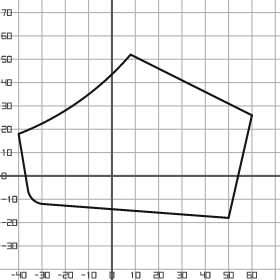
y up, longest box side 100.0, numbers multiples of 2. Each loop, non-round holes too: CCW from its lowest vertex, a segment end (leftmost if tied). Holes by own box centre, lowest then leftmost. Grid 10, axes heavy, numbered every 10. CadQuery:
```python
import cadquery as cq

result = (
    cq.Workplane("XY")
    .moveTo(50.0, -18.0)
    .lineTo(60.0, 26.0)
    .lineTo(8.0, 52.0)
    .threePointArc((-14.0, 32.0), (-40.0, 18.0))
    .lineTo(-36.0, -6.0)
    .threePointArc((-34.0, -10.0), (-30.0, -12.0))
    .close()
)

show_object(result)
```